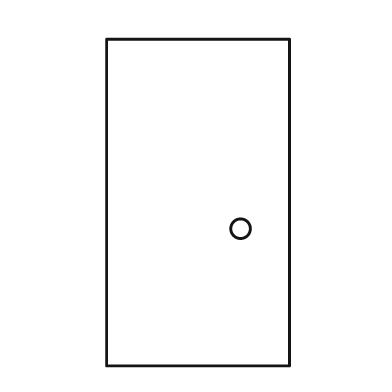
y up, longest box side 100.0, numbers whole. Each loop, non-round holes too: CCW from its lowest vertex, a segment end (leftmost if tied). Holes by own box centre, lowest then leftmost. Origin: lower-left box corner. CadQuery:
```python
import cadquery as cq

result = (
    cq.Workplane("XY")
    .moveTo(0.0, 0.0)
    .lineTo(56.0, 0.0)
    .lineTo(56.0, 100.0)
    .lineTo(0.0, 100.0)
    .close()
    .moveTo(41.0, 42.0)
    .circle(3.0)
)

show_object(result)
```